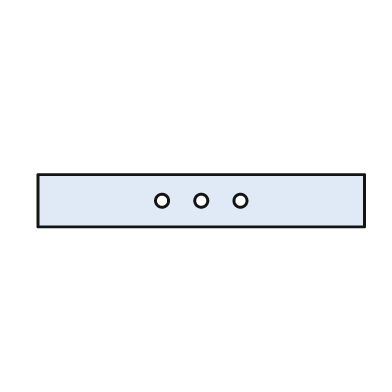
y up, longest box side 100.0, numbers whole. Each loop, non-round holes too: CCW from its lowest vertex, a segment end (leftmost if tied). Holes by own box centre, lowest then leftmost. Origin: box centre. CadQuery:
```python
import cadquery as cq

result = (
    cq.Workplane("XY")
    .moveTo(-50.0, -8.0)
    .lineTo(50.0, -8.0)
    .lineTo(50.0, 8.0)
    .lineTo(-50.0, 8.0)
    .close()
    .moveTo(-12.0, 0.0)
    .circle(2.0)
    .moveTo(0.0, 0.0)
    .circle(2.0)
    .moveTo(12.0, 0.0)
    .circle(2.0)
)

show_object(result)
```